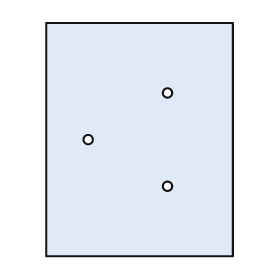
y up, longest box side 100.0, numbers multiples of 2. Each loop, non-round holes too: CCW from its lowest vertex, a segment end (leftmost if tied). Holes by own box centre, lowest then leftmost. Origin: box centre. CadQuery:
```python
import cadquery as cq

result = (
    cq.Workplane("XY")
    .moveTo(-40.0, -50.0)
    .lineTo(40.0, -50.0)
    .lineTo(40.0, 50.0)
    .lineTo(-40.0, 50.0)
    .close()
    .moveTo(12.0, -20.0)
    .circle(2.0)
    .moveTo(-22.0, 0.0)
    .circle(2.0)
    .moveTo(12.0, 20.0)
    .circle(2.0)
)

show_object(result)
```